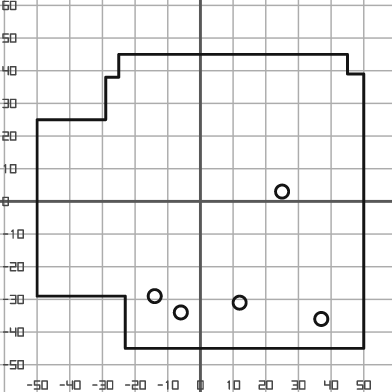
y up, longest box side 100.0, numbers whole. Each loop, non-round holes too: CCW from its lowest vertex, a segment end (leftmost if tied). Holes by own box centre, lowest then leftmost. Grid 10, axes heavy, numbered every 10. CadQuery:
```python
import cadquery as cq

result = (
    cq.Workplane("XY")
    .moveTo(-23.0, -45.0)
    .lineTo(50.0, -45.0)
    .lineTo(50.0, 39.0)
    .lineTo(45.0, 39.0)
    .lineTo(45.0, 45.0)
    .lineTo(-25.0, 45.0)
    .lineTo(-25.0, 38.0)
    .lineTo(-29.0, 38.0)
    .lineTo(-29.0, 25.0)
    .lineTo(-50.0, 25.0)
    .lineTo(-50.0, -29.0)
    .lineTo(-23.0, -29.0)
    .close()
    .moveTo(37.0, -36.0)
    .circle(2.0)
    .moveTo(-6.0, -34.0)
    .circle(2.0)
    .moveTo(12.0, -31.0)
    .circle(2.0)
    .moveTo(-14.0, -29.0)
    .circle(2.0)
    .moveTo(25.0, 3.0)
    .circle(2.0)
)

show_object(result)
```